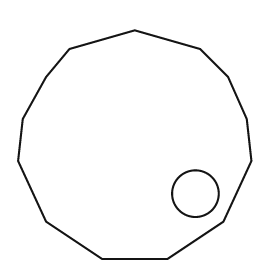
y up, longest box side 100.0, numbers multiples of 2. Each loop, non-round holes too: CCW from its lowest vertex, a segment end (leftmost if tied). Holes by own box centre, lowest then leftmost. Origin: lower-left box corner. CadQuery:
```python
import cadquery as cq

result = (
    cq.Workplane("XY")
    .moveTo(36.0, 0.0)
    .lineTo(64.0, 0.0)
    .lineTo(88.0, 16.0)
    .lineTo(100.0, 42.0)
    .lineTo(98.0, 60.0)
    .lineTo(90.0, 78.0)
    .lineTo(78.0, 90.0)
    .lineTo(50.0, 98.0)
    .lineTo(22.0, 90.0)
    .lineTo(12.0, 78.0)
    .lineTo(2.0, 60.0)
    .lineTo(0.0, 42.0)
    .lineTo(12.0, 16.0)
    .close()
    .moveTo(76.0, 28.0)
    .circle(10.0)
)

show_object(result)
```